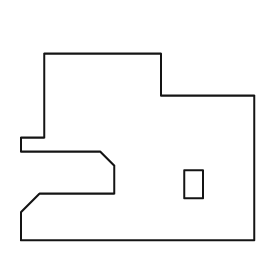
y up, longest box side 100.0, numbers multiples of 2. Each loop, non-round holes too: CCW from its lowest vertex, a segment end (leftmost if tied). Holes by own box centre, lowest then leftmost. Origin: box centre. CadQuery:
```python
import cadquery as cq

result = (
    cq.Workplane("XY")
    .moveTo(-50.0, -40.0)
    .lineTo(50.0, -40.0)
    .lineTo(50.0, 22.0)
    .lineTo(10.0, 22.0)
    .lineTo(10.0, 40.0)
    .lineTo(-40.0, 40.0)
    .lineTo(-40.0, 4.0)
    .lineTo(-50.0, 4.0)
    .lineTo(-50.0, -2.0)
    .lineTo(-16.0, -2.0)
    .lineTo(-10.0, -8.0)
    .lineTo(-10.0, -20.0)
    .lineTo(-42.0, -20.0)
    .lineTo(-50.0, -28.0)
    .close()
    .moveTo(20.0, -22.0)
    .lineTo(28.0, -22.0)
    .lineTo(28.0, -10.0)
    .lineTo(20.0, -10.0)
    .close()
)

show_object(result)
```